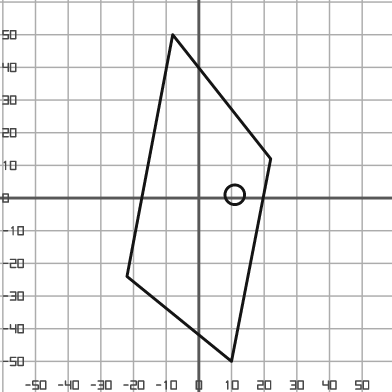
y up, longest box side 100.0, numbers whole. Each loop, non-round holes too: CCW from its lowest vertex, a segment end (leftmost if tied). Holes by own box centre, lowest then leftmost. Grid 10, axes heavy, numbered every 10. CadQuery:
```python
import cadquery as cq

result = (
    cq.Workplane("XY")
    .moveTo(10.0, -50.0)
    .lineTo(22.0, 12.0)
    .lineTo(-8.0, 50.0)
    .lineTo(-22.0, -24.0)
    .close()
    .moveTo(11.0, 1.0)
    .circle(3.0)
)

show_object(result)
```